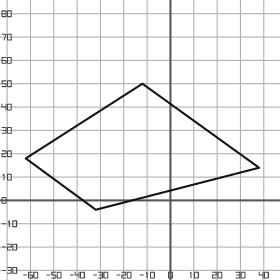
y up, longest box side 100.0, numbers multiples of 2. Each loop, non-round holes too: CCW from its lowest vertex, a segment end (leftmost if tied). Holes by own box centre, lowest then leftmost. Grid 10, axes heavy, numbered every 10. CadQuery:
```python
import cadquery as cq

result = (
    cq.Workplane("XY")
    .moveTo(-32.0, -4.0)
    .lineTo(38.0, 14.0)
    .lineTo(-12.0, 50.0)
    .lineTo(-62.0, 18.0)
    .close()
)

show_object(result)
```